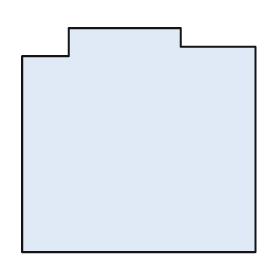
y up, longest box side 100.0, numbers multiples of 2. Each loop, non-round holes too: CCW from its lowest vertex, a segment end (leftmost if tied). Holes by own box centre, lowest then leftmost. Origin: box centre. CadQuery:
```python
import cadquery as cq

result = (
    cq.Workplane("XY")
    .moveTo(-50.0, -48.0)
    .lineTo(50.0, -48.0)
    .lineTo(50.0, 40.0)
    .lineTo(18.0, 40.0)
    .lineTo(18.0, 48.0)
    .lineTo(-30.0, 48.0)
    .lineTo(-30.0, 36.0)
    .lineTo(-50.0, 36.0)
    .close()
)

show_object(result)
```